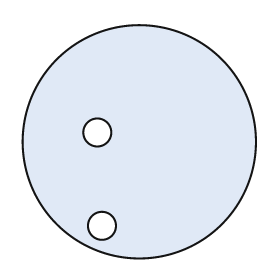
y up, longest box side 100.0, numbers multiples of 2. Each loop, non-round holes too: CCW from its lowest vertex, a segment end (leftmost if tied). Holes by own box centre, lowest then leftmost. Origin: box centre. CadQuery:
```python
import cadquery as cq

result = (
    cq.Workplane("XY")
    .moveTo(0.0, 0.0)
    .circle(50.0)
    .moveTo(-16.0, -36.0)
    .circle(6.0)
    .moveTo(-18.0, 4.0)
    .circle(6.0)
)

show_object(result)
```